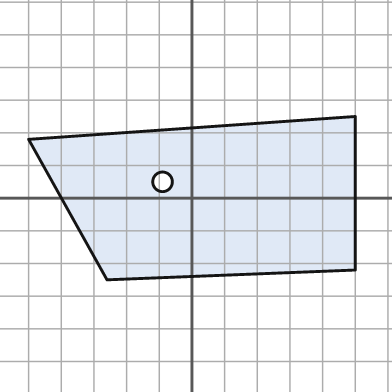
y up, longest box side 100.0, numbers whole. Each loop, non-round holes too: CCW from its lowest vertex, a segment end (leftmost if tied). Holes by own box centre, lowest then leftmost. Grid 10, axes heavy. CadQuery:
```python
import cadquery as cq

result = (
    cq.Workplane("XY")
    .moveTo(-26.0, -25.0)
    .lineTo(50.0, -22.0)
    .lineTo(50.0, 25.0)
    .lineTo(-50.0, 18.0)
    .close()
    .moveTo(-9.0, 5.0)
    .circle(3.0)
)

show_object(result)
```